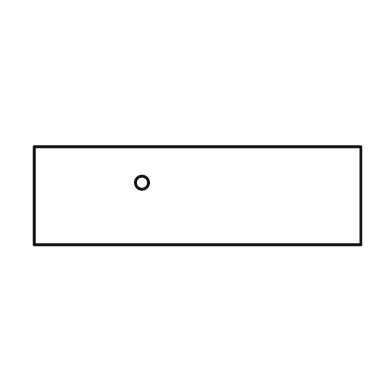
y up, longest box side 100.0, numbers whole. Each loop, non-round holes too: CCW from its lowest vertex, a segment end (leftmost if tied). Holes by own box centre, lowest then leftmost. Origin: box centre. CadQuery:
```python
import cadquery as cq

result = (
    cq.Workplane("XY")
    .moveTo(-50.0, -15.0)
    .lineTo(50.0, -15.0)
    .lineTo(50.0, 15.0)
    .lineTo(-50.0, 15.0)
    .close()
    .moveTo(-17.0, 4.0)
    .circle(2.0)
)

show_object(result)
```